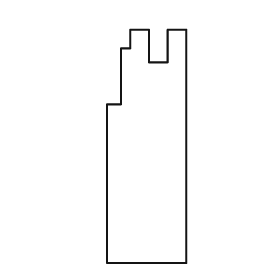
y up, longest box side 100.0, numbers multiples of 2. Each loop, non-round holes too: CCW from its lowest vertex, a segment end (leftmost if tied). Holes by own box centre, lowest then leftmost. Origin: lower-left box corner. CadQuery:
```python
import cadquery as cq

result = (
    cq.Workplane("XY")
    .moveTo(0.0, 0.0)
    .lineTo(34.0, 0.0)
    .lineTo(34.0, 100.0)
    .lineTo(26.0, 100.0)
    .lineTo(26.0, 86.0)
    .lineTo(18.0, 86.0)
    .lineTo(18.0, 100.0)
    .lineTo(10.0, 100.0)
    .lineTo(10.0, 92.0)
    .lineTo(6.0, 92.0)
    .lineTo(6.0, 68.0)
    .lineTo(0.0, 68.0)
    .close()
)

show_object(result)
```